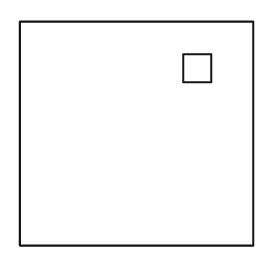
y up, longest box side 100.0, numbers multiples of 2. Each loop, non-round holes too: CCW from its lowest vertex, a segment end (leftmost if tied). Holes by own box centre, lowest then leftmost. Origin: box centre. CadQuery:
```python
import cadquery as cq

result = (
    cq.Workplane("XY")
    .moveTo(-50.0, -48.0)
    .lineTo(50.0, -48.0)
    .lineTo(50.0, 48.0)
    .lineTo(-50.0, 48.0)
    .close()
    .moveTo(20.0, 22.0)
    .lineTo(32.0, 22.0)
    .lineTo(32.0, 34.0)
    .lineTo(20.0, 34.0)
    .close()
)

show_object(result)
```